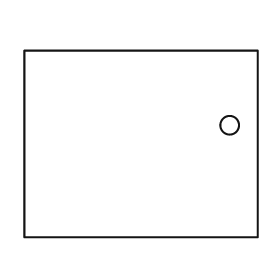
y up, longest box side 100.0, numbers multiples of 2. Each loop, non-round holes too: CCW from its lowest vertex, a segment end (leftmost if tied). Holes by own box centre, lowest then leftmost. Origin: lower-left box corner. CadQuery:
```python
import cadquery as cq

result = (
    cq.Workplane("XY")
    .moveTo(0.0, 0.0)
    .lineTo(100.0, 0.0)
    .lineTo(100.0, 80.0)
    .lineTo(0.0, 80.0)
    .close()
    .moveTo(88.0, 48.0)
    .circle(4.0)
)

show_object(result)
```